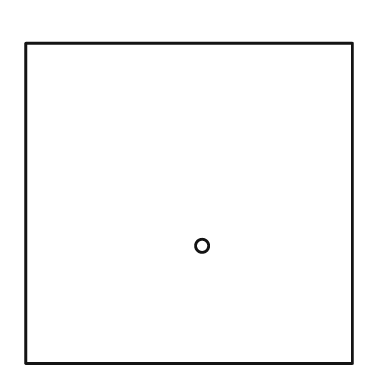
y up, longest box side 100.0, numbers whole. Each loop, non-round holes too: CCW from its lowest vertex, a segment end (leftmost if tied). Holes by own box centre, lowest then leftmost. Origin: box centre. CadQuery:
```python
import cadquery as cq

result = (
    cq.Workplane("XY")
    .moveTo(-50.0, -49.0)
    .lineTo(50.0, -49.0)
    .lineTo(50.0, 49.0)
    .lineTo(-50.0, 49.0)
    .close()
    .moveTo(4.0, -13.0)
    .circle(2.0)
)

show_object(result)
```